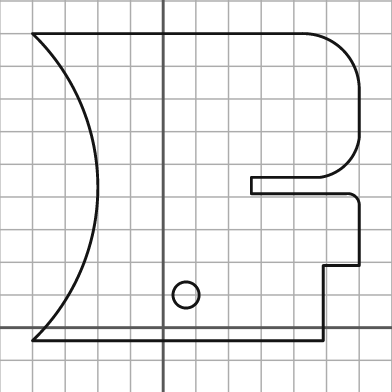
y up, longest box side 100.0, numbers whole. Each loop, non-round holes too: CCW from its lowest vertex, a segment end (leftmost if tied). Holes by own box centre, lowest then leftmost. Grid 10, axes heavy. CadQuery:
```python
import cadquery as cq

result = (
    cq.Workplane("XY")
    .moveTo(-40.0, -4.0)
    .lineTo(49.0, -4.0)
    .lineTo(49.0, 19.0)
    .lineTo(60.0, 19.0)
    .lineTo(60.0, 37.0)
    .threePointArc((59.0, 40.0), (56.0, 41.0))
    .lineTo(27.0, 41.0)
    .lineTo(27.0, 46.0)
    .lineTo(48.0, 46.0)
    .threePointArc((56.0, 50.0), (60.0, 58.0))
    .lineTo(60.0, 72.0)
    .threePointArc((55.0, 85.0), (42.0, 90.0))
    .lineTo(-40.0, 90.0)
    .threePointArc((-20.0, 43.0), (-40.0, -4.0))
    .close()
    .moveTo(7.0, 10.0)
    .circle(4.0)
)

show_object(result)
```